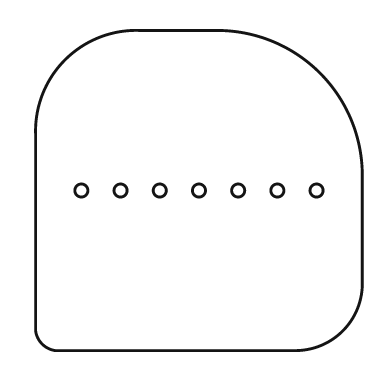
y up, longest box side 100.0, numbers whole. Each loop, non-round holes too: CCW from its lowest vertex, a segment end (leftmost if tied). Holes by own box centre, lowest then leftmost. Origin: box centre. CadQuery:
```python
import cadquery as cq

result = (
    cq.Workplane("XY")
    .moveTo(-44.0, -49.0)
    .lineTo(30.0, -49.0)
    .threePointArc((44.0, -43.0), (50.0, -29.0))
    .lineTo(50.0, 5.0)
    .threePointArc((37.0, 36.0), (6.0, 49.0))
    .lineTo(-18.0, 49.0)
    .threePointArc((-41.0, 40.0), (-50.0, 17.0))
    .lineTo(-50.0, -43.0)
    .threePointArc((-48.0, -47.0), (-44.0, -49.0))
    .close()
    .moveTo(-36.0, 0.0)
    .circle(2.0)
    .moveTo(-24.0, 0.0)
    .circle(2.0)
    .moveTo(-12.0, 0.0)
    .circle(2.0)
    .moveTo(0.0, 0.0)
    .circle(2.0)
    .moveTo(12.0, 0.0)
    .circle(2.0)
    .moveTo(24.0, 0.0)
    .circle(2.0)
    .moveTo(36.0, 0.0)
    .circle(2.0)
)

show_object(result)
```